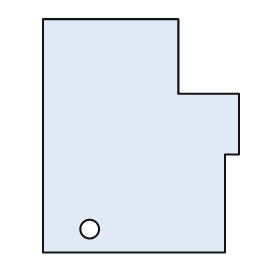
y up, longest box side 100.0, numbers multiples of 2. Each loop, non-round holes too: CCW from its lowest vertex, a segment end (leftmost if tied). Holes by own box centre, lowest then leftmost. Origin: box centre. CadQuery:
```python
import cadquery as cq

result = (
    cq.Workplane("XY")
    .moveTo(-42.0, -50.0)
    .lineTo(36.0, -50.0)
    .lineTo(36.0, -8.0)
    .lineTo(42.0, -8.0)
    .lineTo(42.0, 18.0)
    .lineTo(16.0, 18.0)
    .lineTo(16.0, 50.0)
    .lineTo(-42.0, 50.0)
    .close()
    .moveTo(-22.0, -40.0)
    .circle(4.0)
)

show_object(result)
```